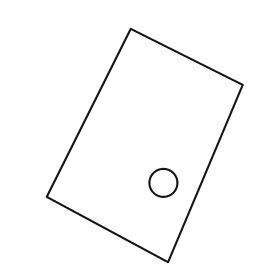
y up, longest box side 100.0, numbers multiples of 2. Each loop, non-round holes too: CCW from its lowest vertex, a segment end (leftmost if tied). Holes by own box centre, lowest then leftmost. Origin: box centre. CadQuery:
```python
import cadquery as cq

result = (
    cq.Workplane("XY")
    .moveTo(10.0, -50.0)
    .lineTo(42.0, 26.0)
    .lineTo(-6.0, 50.0)
    .lineTo(-42.0, -22.0)
    .close()
    .moveTo(8.0, -16.0)
    .circle(6.0)
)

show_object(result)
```